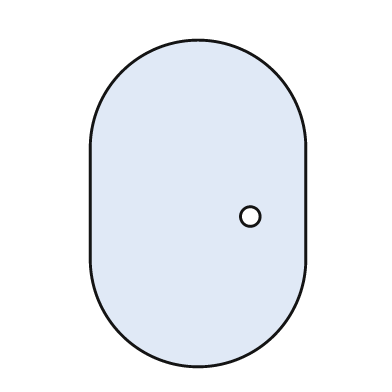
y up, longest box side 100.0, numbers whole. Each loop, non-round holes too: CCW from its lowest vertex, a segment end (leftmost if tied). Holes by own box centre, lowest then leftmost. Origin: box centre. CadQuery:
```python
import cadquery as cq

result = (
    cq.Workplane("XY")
    .moveTo(-33.0, -17.0)
    .threePointArc((0.0, -50.0), (33.0, -17.0))
    .lineTo(33.0, 17.0)
    .threePointArc((0.0, 50.0), (-33.0, 17.0))
    .close()
    .moveTo(16.0, -4.0)
    .circle(3.0)
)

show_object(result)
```